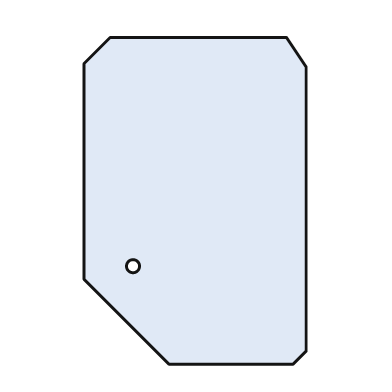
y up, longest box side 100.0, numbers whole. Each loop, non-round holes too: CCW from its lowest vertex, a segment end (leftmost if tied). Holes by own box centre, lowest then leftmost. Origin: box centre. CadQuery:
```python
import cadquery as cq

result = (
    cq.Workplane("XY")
    .moveTo(-8.0, -50.0)
    .lineTo(30.0, -50.0)
    .lineTo(34.0, -46.0)
    .lineTo(34.0, 41.0)
    .lineTo(28.0, 50.0)
    .lineTo(-26.0, 50.0)
    .lineTo(-34.0, 42.0)
    .lineTo(-34.0, -24.0)
    .close()
    .moveTo(-19.0, -20.0)
    .circle(2.0)
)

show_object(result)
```